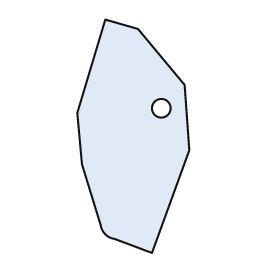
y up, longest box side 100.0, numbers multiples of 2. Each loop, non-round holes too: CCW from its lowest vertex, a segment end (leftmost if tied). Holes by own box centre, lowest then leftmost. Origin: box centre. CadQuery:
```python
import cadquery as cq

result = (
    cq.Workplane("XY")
    .moveTo(8.0, -50.0)
    .lineTo(24.0, -6.0)
    .lineTo(22.0, 22.0)
    .lineTo(2.0, 46.0)
    .lineTo(-12.0, 50.0)
    .lineTo(-24.0, 10.0)
    .lineTo(-22.0, -12.0)
    .lineTo(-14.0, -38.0)
    .threePointArc((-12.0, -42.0), (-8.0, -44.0))
    .close()
    .moveTo(12.0, 12.0)
    .circle(4.0)
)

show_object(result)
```